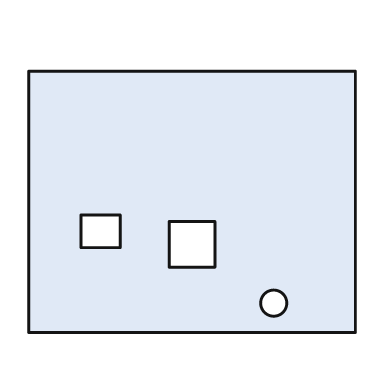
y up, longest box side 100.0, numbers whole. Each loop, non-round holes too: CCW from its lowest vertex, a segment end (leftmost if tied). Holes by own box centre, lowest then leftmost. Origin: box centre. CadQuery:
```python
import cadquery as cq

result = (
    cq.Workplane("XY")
    .moveTo(-50.0, -40.0)
    .lineTo(50.0, -40.0)
    .lineTo(50.0, 40.0)
    .lineTo(-50.0, 40.0)
    .close()
    .moveTo(25.0, -31.0)
    .circle(4.0)
    .moveTo(-7.0, -20.0)
    .lineTo(7.0, -20.0)
    .lineTo(7.0, -6.0)
    .lineTo(-7.0, -6.0)
    .close()
    .moveTo(-34.0, -14.0)
    .lineTo(-22.0, -14.0)
    .lineTo(-22.0, -4.0)
    .lineTo(-34.0, -4.0)
    .close()
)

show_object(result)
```